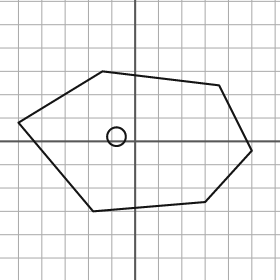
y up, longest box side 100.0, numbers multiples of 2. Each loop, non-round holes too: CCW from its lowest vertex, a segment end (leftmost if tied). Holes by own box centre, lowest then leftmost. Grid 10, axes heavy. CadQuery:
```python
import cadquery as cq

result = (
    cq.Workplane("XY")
    .moveTo(-18.0, -30.0)
    .lineTo(30.0, -26.0)
    .lineTo(50.0, -4.0)
    .lineTo(36.0, 24.0)
    .lineTo(-14.0, 30.0)
    .lineTo(-50.0, 8.0)
    .close()
    .moveTo(-8.0, 2.0)
    .circle(4.0)
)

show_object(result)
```